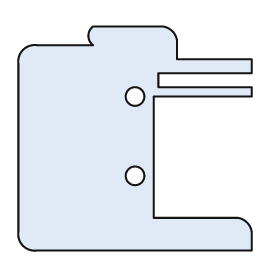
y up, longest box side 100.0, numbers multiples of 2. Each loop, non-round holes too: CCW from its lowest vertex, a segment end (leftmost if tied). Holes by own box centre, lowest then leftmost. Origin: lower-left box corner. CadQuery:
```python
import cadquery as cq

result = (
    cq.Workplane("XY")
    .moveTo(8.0, 0.0)
    .lineTo(100.0, 0.0)
    .lineTo(100.0, 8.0)
    .threePointArc((98.0, 12.0), (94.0, 14.0))
    .lineTo(58.0, 14.0)
    .lineTo(58.0, 66.0)
    .lineTo(100.0, 66.0)
    .lineTo(100.0, 70.0)
    .lineTo(60.0, 70.0)
    .lineTo(60.0, 76.0)
    .lineTo(100.0, 76.0)
    .lineTo(100.0, 82.0)
    .lineTo(68.0, 82.0)
    .lineTo(68.0, 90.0)
    .threePointArc((66.0, 94.0), (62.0, 96.0))
    .lineTo(32.0, 96.0)
    .threePointArc((30.0, 92.0), (32.0, 88.0))
    .lineTo(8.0, 88.0)
    .threePointArc((2.0, 86.0), (0.0, 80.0))
    .lineTo(0.0, 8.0)
    .threePointArc((2.0, 2.0), (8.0, 0.0))
    .close()
    .moveTo(50.0, 32.0)
    .circle(4.0)
    .moveTo(50.0, 66.0)
    .circle(4.0)
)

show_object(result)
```